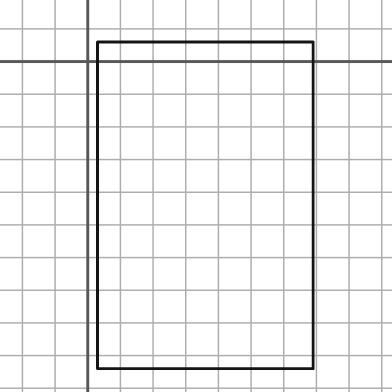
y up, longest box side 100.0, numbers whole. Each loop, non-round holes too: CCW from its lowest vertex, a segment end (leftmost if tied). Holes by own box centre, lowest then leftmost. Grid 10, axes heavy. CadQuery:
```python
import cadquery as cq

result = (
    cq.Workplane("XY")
    .moveTo(3.0, -94.0)
    .lineTo(69.0, -94.0)
    .lineTo(69.0, 6.0)
    .lineTo(3.0, 6.0)
    .close()
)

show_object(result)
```